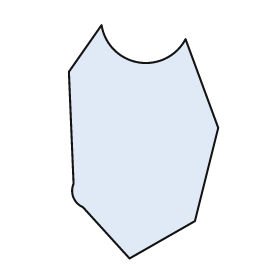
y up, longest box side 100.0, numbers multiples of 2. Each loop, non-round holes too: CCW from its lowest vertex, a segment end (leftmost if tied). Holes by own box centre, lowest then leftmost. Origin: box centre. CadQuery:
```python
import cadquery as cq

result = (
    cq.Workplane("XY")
    .moveTo(-6.0, -50.0)
    .lineTo(22.0, -34.0)
    .lineTo(32.0, 6.0)
    .lineTo(18.0, 44.0)
    .threePointArc((-2.0, 34.0), (-18.0, 50.0))
    .lineTo(-32.0, 30.0)
    .lineTo(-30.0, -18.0)
    .threePointArc((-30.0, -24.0), (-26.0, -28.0))
    .close()
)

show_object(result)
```